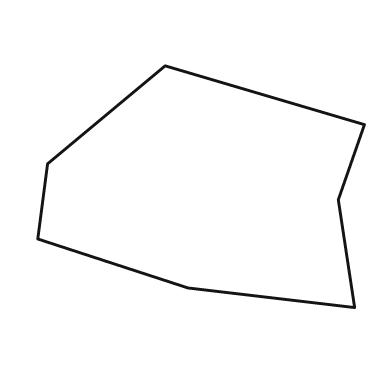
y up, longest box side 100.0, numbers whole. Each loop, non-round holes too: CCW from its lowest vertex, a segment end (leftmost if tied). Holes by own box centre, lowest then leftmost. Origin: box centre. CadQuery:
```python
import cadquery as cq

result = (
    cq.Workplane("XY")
    .moveTo(47.0, -37.0)
    .lineTo(42.0, -4.0)
    .lineTo(50.0, 19.0)
    .lineTo(-11.0, 37.0)
    .lineTo(-47.0, 7.0)
    .lineTo(-50.0, -16.0)
    .lineTo(-4.0, -31.0)
    .close()
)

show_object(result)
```